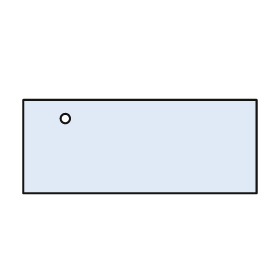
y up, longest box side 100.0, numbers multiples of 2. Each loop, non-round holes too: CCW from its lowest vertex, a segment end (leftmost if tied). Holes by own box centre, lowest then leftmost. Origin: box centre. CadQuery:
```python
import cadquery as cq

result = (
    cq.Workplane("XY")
    .moveTo(-50.0, -20.0)
    .lineTo(50.0, -20.0)
    .lineTo(50.0, 20.0)
    .lineTo(-50.0, 20.0)
    .close()
    .moveTo(-32.0, 12.0)
    .circle(2.0)
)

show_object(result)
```